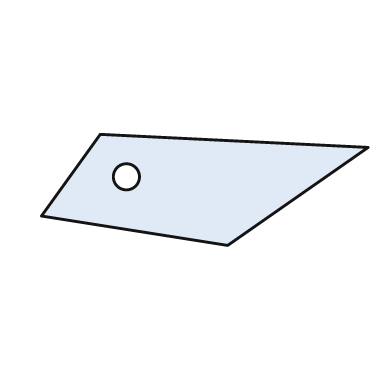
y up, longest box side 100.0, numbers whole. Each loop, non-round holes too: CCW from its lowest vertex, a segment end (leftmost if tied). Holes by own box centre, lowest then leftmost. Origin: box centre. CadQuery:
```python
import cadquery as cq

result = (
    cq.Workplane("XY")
    .moveTo(7.0, -17.0)
    .lineTo(50.0, 13.0)
    .lineTo(-32.0, 17.0)
    .lineTo(-50.0, -8.0)
    .close()
    .moveTo(-24.0, 4.0)
    .circle(4.0)
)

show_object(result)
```